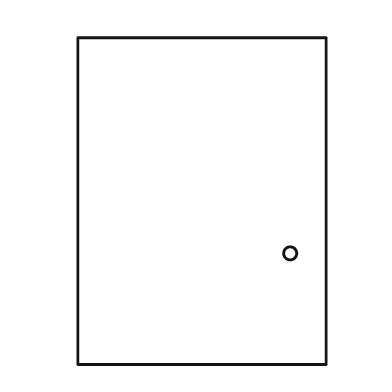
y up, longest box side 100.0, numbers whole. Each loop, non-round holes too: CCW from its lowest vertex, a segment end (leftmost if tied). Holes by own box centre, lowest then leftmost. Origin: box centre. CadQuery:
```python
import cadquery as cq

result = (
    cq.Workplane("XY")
    .moveTo(-38.0, -50.0)
    .lineTo(38.0, -50.0)
    .lineTo(38.0, 50.0)
    .lineTo(-38.0, 50.0)
    .close()
    .moveTo(27.0, -16.0)
    .circle(2.0)
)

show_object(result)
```